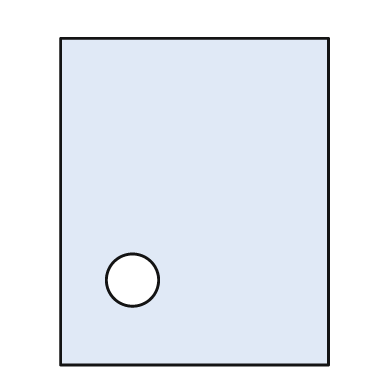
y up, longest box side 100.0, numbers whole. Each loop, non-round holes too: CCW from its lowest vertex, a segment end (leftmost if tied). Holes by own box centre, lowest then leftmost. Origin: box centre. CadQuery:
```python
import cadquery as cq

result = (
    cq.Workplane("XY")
    .moveTo(-41.0, -50.0)
    .lineTo(41.0, -50.0)
    .lineTo(41.0, 50.0)
    .lineTo(-41.0, 50.0)
    .close()
    .moveTo(-19.0, -24.0)
    .circle(8.0)
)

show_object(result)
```